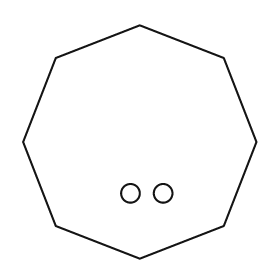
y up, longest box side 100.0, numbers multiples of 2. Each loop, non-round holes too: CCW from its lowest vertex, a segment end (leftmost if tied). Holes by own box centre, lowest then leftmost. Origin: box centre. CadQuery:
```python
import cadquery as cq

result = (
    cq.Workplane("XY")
    .moveTo(0.0, -50.0)
    .lineTo(36.0, -36.0)
    .lineTo(50.0, 0.0)
    .lineTo(36.0, 36.0)
    .lineTo(0.0, 50.0)
    .lineTo(-36.0, 36.0)
    .lineTo(-50.0, 0.0)
    .lineTo(-36.0, -36.0)
    .close()
    .moveTo(-4.0, -22.0)
    .circle(4.0)
    .moveTo(10.0, -22.0)
    .circle(4.0)
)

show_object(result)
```